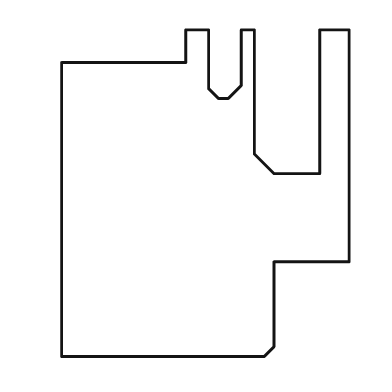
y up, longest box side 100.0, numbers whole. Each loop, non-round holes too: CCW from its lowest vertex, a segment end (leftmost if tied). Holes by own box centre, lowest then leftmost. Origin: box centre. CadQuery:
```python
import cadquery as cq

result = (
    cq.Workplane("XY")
    .moveTo(-44.0, -50.0)
    .lineTo(18.0, -50.0)
    .lineTo(21.0, -47.0)
    .lineTo(21.0, -21.0)
    .lineTo(44.0, -21.0)
    .lineTo(44.0, 50.0)
    .lineTo(35.0, 50.0)
    .lineTo(35.0, 6.0)
    .lineTo(21.0, 6.0)
    .lineTo(15.0, 12.0)
    .lineTo(15.0, 50.0)
    .lineTo(11.0, 50.0)
    .lineTo(11.0, 33.0)
    .lineTo(7.0, 29.0)
    .lineTo(4.0, 29.0)
    .lineTo(1.0, 32.0)
    .lineTo(1.0, 50.0)
    .lineTo(-6.0, 50.0)
    .lineTo(-6.0, 40.0)
    .lineTo(-44.0, 40.0)
    .close()
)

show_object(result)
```